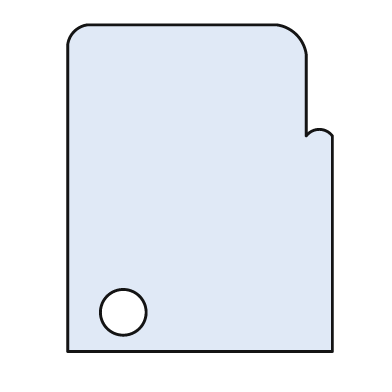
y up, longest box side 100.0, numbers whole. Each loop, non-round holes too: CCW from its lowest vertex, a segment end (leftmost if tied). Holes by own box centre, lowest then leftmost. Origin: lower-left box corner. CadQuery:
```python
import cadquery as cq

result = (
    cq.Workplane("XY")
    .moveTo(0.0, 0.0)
    .lineTo(81.0, 0.0)
    .lineTo(81.0, 66.0)
    .threePointArc((77.0, 68.0), (73.0, 66.0))
    .lineTo(73.0, 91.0)
    .threePointArc((70.0, 97.0), (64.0, 100.0))
    .lineTo(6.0, 100.0)
    .threePointArc((2.0, 98.0), (0.0, 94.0))
    .close()
    .moveTo(17.0, 12.0)
    .circle(7.0)
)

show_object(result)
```